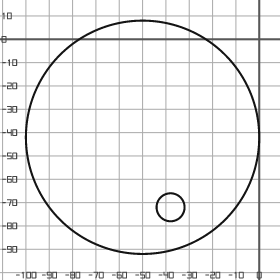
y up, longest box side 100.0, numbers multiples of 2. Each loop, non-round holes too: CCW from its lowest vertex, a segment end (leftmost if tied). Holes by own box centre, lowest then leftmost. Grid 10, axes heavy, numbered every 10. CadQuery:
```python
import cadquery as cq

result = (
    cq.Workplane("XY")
    .moveTo(-50.0, -42.0)
    .circle(50.0)
    .moveTo(-38.0, -72.0)
    .circle(6.0)
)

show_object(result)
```